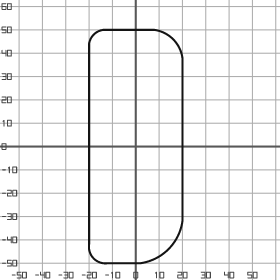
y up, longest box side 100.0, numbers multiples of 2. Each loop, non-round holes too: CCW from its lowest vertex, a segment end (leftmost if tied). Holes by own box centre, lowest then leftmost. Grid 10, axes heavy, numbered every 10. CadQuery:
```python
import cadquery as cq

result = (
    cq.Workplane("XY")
    .moveTo(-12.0, -50.0)
    .lineTo(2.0, -50.0)
    .threePointArc((14.0, -44.0), (20.0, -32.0))
    .lineTo(20.0, 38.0)
    .threePointArc((16.0, 46.0), (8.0, 50.0))
    .lineTo(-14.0, 50.0)
    .threePointArc((-18.0, 48.0), (-20.0, 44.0))
    .lineTo(-20.0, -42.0)
    .threePointArc((-18.0, -48.0), (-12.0, -50.0))
    .close()
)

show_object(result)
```